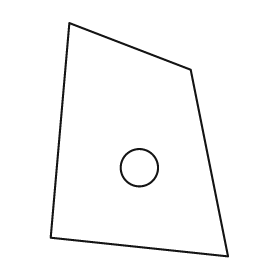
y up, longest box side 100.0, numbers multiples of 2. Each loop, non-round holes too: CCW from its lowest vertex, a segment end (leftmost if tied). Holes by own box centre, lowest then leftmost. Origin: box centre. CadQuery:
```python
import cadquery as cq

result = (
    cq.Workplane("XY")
    .moveTo(38.0, -50.0)
    .lineTo(22.0, 30.0)
    .lineTo(-30.0, 50.0)
    .lineTo(-38.0, -42.0)
    .close()
    .moveTo(0.0, -12.0)
    .circle(8.0)
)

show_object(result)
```